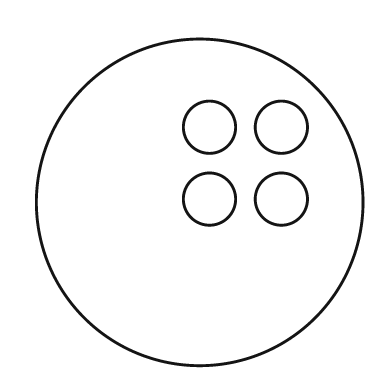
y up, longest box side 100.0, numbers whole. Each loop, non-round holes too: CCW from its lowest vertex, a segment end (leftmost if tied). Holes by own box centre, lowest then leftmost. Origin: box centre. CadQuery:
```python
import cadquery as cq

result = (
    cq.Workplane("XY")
    .moveTo(0.0, 0.0)
    .circle(50.0)
    .moveTo(3.0, 1.0)
    .circle(8.0)
    .moveTo(25.0, 1.0)
    .circle(8.0)
    .moveTo(3.0, 23.0)
    .circle(8.0)
    .moveTo(25.0, 23.0)
    .circle(8.0)
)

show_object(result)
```